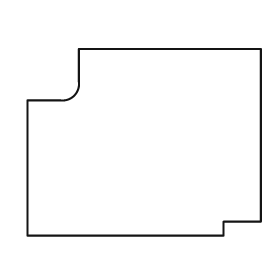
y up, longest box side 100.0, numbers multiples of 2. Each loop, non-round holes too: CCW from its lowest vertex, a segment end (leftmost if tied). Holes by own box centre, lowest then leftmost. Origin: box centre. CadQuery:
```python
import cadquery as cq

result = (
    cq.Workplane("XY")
    .moveTo(-50.0, -40.0)
    .lineTo(34.0, -40.0)
    .lineTo(34.0, -34.0)
    .lineTo(50.0, -34.0)
    .lineTo(50.0, 40.0)
    .lineTo(-28.0, 40.0)
    .lineTo(-28.0, 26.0)
    .threePointArc((-30.0, 20.0), (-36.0, 18.0))
    .lineTo(-50.0, 18.0)
    .close()
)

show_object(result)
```